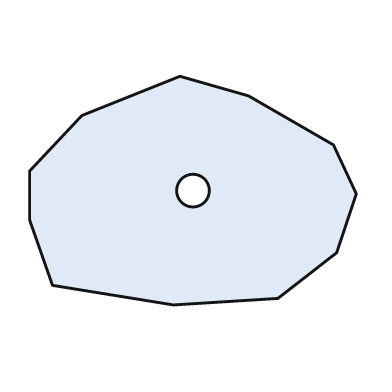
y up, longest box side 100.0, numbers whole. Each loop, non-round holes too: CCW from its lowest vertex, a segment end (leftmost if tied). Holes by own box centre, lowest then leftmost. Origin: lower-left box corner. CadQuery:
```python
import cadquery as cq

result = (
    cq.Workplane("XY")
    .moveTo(44.0, 0.0)
    .lineTo(76.0, 2.0)
    .lineTo(94.0, 16.0)
    .lineTo(100.0, 34.0)
    .lineTo(93.0, 49.0)
    .lineTo(67.0, 64.0)
    .lineTo(46.0, 70.0)
    .lineTo(16.0, 58.0)
    .lineTo(0.0, 41.0)
    .lineTo(0.0, 26.0)
    .lineTo(7.0, 6.0)
    .close()
    .moveTo(50.0, 35.0)
    .circle(5.0)
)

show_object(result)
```